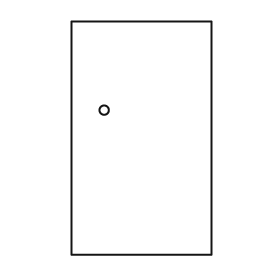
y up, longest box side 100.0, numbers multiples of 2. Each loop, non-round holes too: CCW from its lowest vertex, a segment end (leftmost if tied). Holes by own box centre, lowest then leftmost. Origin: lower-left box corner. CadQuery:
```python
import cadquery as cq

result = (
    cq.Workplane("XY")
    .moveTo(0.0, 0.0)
    .lineTo(60.0, 0.0)
    .lineTo(60.0, 100.0)
    .lineTo(0.0, 100.0)
    .close()
    .moveTo(14.0, 62.0)
    .circle(2.0)
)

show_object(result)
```